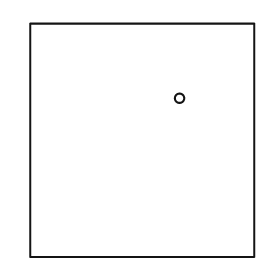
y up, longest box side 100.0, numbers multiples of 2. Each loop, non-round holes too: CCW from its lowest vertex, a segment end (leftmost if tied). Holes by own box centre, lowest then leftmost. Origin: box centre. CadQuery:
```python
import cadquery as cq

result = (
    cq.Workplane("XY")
    .moveTo(-48.0, -50.0)
    .lineTo(48.0, -50.0)
    .lineTo(48.0, 50.0)
    .lineTo(-48.0, 50.0)
    .close()
    .moveTo(16.0, 18.0)
    .circle(2.0)
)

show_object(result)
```